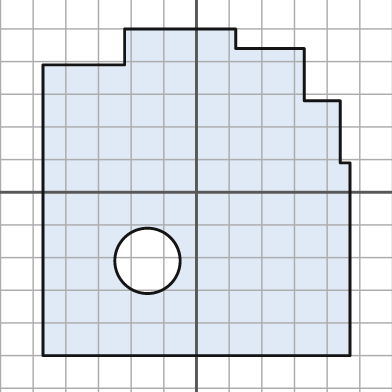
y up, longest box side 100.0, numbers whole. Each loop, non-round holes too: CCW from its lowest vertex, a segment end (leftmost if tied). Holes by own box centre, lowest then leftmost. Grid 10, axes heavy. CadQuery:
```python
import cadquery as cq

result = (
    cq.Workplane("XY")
    .moveTo(-47.0, -50.0)
    .lineTo(47.0, -50.0)
    .lineTo(47.0, 9.0)
    .lineTo(44.0, 9.0)
    .lineTo(44.0, 28.0)
    .lineTo(33.0, 28.0)
    .lineTo(33.0, 44.0)
    .lineTo(12.0, 44.0)
    .lineTo(12.0, 50.0)
    .lineTo(-22.0, 50.0)
    .lineTo(-22.0, 39.0)
    .lineTo(-47.0, 39.0)
    .close()
    .moveTo(-15.0, -21.0)
    .circle(10.0)
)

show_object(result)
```